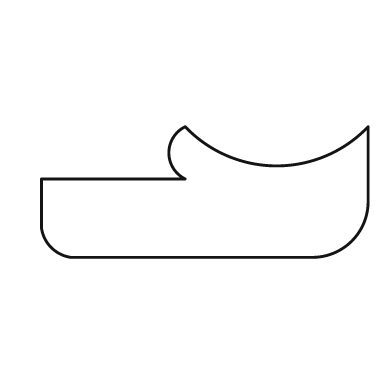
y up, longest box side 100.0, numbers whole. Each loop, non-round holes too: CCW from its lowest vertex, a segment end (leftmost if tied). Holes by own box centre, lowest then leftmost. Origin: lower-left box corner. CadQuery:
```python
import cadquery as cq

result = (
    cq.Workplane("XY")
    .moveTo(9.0, 0.0)
    .lineTo(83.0, 0.0)
    .threePointArc((95.0, 5.0), (100.0, 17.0))
    .lineTo(100.0, 40.0)
    .threePointArc((72.0, 28.0), (44.0, 40.0))
    .threePointArc((39.0, 32.0), (44.0, 24.0))
    .lineTo(0.0, 24.0)
    .lineTo(0.0, 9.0)
    .threePointArc((3.0, 3.0), (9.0, 0.0))
    .close()
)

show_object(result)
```